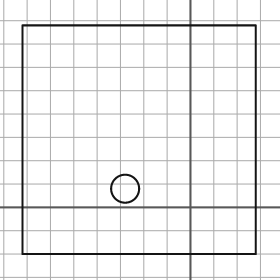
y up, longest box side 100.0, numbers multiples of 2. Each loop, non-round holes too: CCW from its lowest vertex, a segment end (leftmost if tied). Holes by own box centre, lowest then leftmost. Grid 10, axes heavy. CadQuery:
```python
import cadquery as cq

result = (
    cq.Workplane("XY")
    .moveTo(-72.0, -20.0)
    .lineTo(28.0, -20.0)
    .lineTo(28.0, 78.0)
    .lineTo(-72.0, 78.0)
    .close()
    .moveTo(-28.0, 8.0)
    .circle(6.0)
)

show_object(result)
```